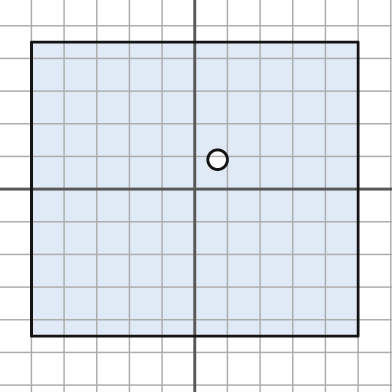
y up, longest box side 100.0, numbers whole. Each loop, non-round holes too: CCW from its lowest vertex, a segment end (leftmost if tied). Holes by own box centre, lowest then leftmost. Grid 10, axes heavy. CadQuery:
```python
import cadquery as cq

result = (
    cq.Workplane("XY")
    .moveTo(-50.0, -45.0)
    .lineTo(50.0, -45.0)
    .lineTo(50.0, 45.0)
    .lineTo(-50.0, 45.0)
    .close()
    .moveTo(7.0, 9.0)
    .circle(3.0)
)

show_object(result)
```